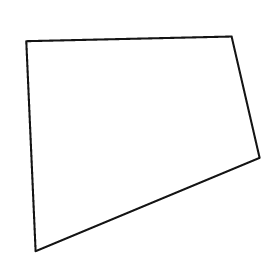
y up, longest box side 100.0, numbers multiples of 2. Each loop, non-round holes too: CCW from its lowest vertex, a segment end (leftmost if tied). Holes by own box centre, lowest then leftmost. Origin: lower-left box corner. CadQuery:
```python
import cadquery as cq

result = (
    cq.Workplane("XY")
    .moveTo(4.0, 0.0)
    .lineTo(100.0, 40.0)
    .lineTo(88.0, 92.0)
    .lineTo(0.0, 90.0)
    .close()
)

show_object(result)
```